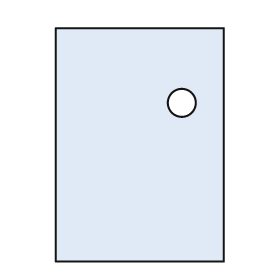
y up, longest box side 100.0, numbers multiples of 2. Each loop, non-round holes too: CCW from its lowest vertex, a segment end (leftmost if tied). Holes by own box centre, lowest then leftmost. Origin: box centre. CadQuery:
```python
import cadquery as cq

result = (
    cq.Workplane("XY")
    .moveTo(-36.0, -50.0)
    .lineTo(36.0, -50.0)
    .lineTo(36.0, 50.0)
    .lineTo(-36.0, 50.0)
    .close()
    .moveTo(18.0, 18.0)
    .circle(6.0)
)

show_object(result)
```